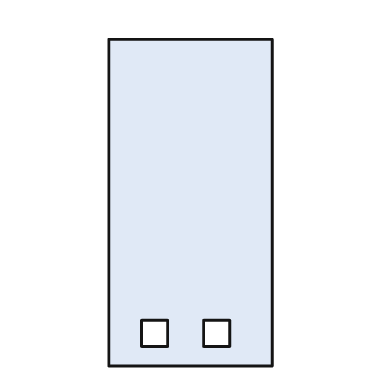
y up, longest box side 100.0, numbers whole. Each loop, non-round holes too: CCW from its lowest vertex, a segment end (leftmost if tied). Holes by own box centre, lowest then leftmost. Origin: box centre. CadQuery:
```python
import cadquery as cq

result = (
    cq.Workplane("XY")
    .moveTo(-25.0, -50.0)
    .lineTo(25.0, -50.0)
    .lineTo(25.0, 50.0)
    .lineTo(-25.0, 50.0)
    .close()
    .moveTo(-15.0, -44.0)
    .lineTo(-7.0, -44.0)
    .lineTo(-7.0, -36.0)
    .lineTo(-15.0, -36.0)
    .close()
    .moveTo(4.0, -44.0)
    .lineTo(12.0, -44.0)
    .lineTo(12.0, -36.0)
    .lineTo(4.0, -36.0)
    .close()
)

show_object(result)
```